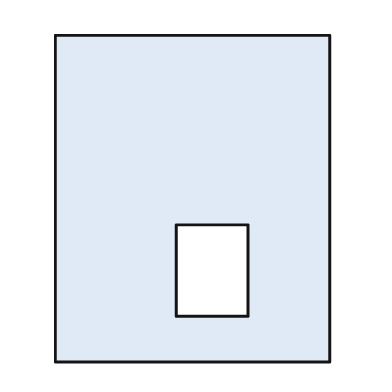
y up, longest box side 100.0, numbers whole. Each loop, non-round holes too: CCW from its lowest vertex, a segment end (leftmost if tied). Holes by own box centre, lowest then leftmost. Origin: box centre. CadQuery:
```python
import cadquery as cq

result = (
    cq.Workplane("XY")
    .moveTo(-42.0, -50.0)
    .lineTo(42.0, -50.0)
    .lineTo(42.0, 50.0)
    .lineTo(-42.0, 50.0)
    .close()
    .moveTo(-5.0, -36.0)
    .lineTo(17.0, -36.0)
    .lineTo(17.0, -8.0)
    .lineTo(-5.0, -8.0)
    .close()
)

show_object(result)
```